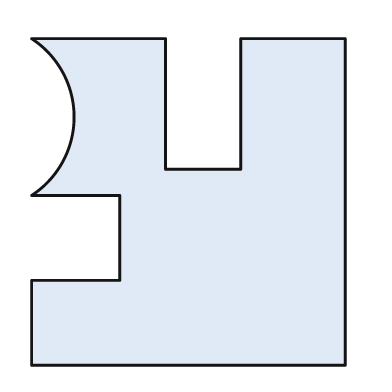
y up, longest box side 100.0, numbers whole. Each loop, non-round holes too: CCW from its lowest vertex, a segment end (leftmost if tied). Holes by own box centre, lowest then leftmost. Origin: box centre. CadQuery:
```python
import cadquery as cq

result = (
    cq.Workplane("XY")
    .moveTo(-48.0, -50.0)
    .lineTo(48.0, -50.0)
    .lineTo(48.0, 50.0)
    .lineTo(16.0, 50.0)
    .lineTo(16.0, 10.0)
    .lineTo(-7.0, 10.0)
    .lineTo(-7.0, 50.0)
    .lineTo(-48.0, 50.0)
    .threePointArc((-35.0, 26.0), (-48.0, 2.0))
    .lineTo(-21.0, 2.0)
    .lineTo(-21.0, -24.0)
    .lineTo(-48.0, -24.0)
    .close()
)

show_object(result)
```